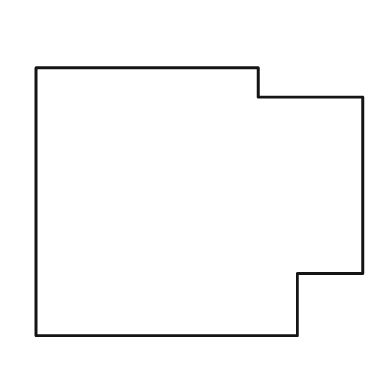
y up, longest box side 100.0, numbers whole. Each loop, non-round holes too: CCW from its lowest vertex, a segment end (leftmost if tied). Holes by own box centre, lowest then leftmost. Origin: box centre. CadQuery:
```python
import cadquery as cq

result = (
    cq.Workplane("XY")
    .moveTo(-50.0, -41.0)
    .lineTo(30.0, -41.0)
    .lineTo(30.0, -22.0)
    .lineTo(50.0, -22.0)
    .lineTo(50.0, 32.0)
    .lineTo(18.0, 32.0)
    .lineTo(18.0, 41.0)
    .lineTo(-50.0, 41.0)
    .close()
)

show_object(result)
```